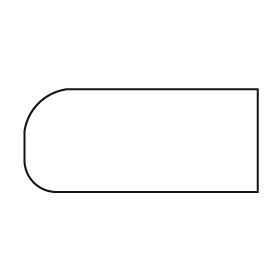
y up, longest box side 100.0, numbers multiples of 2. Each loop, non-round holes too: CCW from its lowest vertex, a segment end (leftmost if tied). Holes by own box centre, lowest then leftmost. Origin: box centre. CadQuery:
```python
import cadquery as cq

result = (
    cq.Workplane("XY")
    .moveTo(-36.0, -22.0)
    .lineTo(50.0, -22.0)
    .lineTo(50.0, 22.0)
    .lineTo(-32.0, 22.0)
    .threePointArc((-44.0, 16.0), (-50.0, 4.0))
    .lineTo(-50.0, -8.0)
    .threePointArc((-46.0, -18.0), (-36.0, -22.0))
    .close()
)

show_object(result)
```